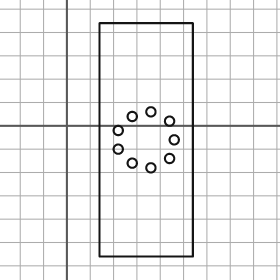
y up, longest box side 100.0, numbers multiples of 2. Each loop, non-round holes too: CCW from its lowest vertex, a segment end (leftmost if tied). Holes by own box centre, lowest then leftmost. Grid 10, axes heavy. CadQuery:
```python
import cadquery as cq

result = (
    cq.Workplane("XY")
    .moveTo(14.0, -56.0)
    .lineTo(54.0, -56.0)
    .lineTo(54.0, 44.0)
    .lineTo(14.0, 44.0)
    .close()
    .moveTo(36.0, -18.0)
    .circle(2.0)
    .moveTo(28.0, -16.0)
    .circle(2.0)
    .moveTo(44.0, -14.0)
    .circle(2.0)
    .moveTo(22.0, -10.0)
    .circle(2.0)
    .moveTo(46.0, -6.0)
    .circle(2.0)
    .moveTo(22.0, -2.0)
    .circle(2.0)
    .moveTo(44.0, 2.0)
    .circle(2.0)
    .moveTo(28.0, 4.0)
    .circle(2.0)
    .moveTo(36.0, 6.0)
    .circle(2.0)
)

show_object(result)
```